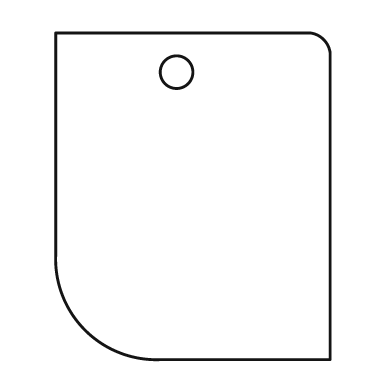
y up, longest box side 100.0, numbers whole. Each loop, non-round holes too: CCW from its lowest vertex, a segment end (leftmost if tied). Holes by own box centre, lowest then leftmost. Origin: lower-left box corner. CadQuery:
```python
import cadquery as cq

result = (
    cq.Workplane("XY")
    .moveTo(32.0, 0.0)
    .lineTo(84.0, 0.0)
    .lineTo(84.0, 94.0)
    .threePointArc((82.0, 98.0), (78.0, 100.0))
    .lineTo(0.0, 100.0)
    .lineTo(0.0, 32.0)
    .threePointArc((9.0, 9.0), (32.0, 0.0))
    .close()
    .moveTo(37.0, 88.0)
    .circle(5.0)
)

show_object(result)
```